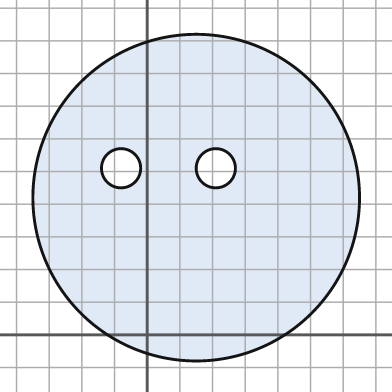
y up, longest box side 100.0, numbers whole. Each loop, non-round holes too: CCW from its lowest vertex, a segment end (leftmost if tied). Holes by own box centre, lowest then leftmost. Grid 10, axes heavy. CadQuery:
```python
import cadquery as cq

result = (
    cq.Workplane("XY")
    .moveTo(15.0, 42.0)
    .circle(50.0)
    .moveTo(-8.0, 51.0)
    .circle(6.0)
    .moveTo(21.0, 51.0)
    .circle(6.0)
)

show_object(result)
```